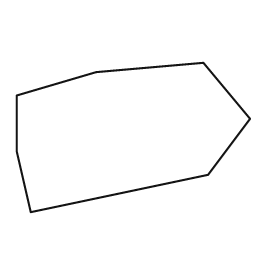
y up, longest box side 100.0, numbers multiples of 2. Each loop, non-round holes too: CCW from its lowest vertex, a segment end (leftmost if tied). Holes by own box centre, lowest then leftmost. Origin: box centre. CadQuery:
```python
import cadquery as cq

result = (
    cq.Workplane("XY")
    .moveTo(-44.0, -32.0)
    .lineTo(32.0, -16.0)
    .lineTo(50.0, 8.0)
    .lineTo(30.0, 32.0)
    .lineTo(-16.0, 28.0)
    .lineTo(-50.0, 18.0)
    .lineTo(-50.0, -6.0)
    .close()
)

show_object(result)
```